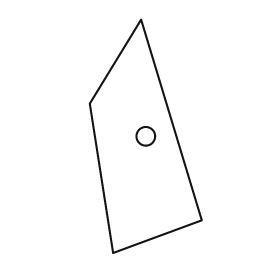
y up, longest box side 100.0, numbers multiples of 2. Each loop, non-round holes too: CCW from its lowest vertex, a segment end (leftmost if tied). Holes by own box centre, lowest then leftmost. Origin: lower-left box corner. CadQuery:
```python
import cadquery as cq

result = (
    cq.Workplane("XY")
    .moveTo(10.0, 0.0)
    .lineTo(48.0, 14.0)
    .lineTo(22.0, 100.0)
    .lineTo(0.0, 64.0)
    .close()
    .moveTo(24.0, 50.0)
    .circle(4.0)
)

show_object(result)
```